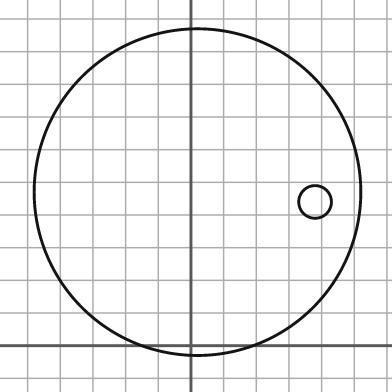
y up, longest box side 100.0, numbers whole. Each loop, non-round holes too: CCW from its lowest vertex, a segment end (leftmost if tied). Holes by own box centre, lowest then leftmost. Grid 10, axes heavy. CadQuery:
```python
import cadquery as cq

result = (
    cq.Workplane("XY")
    .moveTo(2.0, 47.0)
    .circle(50.0)
    .moveTo(38.0, 44.0)
    .circle(5.0)
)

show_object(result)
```